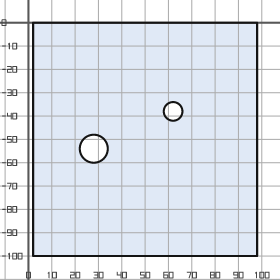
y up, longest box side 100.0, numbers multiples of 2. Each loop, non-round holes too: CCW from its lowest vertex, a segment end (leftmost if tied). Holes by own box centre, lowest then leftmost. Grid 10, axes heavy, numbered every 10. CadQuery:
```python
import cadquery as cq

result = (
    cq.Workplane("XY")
    .moveTo(2.0, -100.0)
    .lineTo(98.0, -100.0)
    .lineTo(98.0, 0.0)
    .lineTo(2.0, 0.0)
    .close()
    .moveTo(28.0, -54.0)
    .circle(6.0)
    .moveTo(62.0, -38.0)
    .circle(4.0)
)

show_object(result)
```